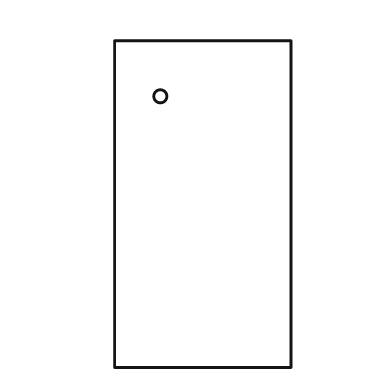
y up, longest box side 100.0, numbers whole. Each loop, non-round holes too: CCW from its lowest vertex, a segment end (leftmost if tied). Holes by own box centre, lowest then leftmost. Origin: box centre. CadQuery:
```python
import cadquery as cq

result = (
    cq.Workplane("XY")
    .moveTo(-27.0, -50.0)
    .lineTo(27.0, -50.0)
    .lineTo(27.0, 50.0)
    .lineTo(-27.0, 50.0)
    .close()
    .moveTo(-13.0, 33.0)
    .circle(2.0)
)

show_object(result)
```